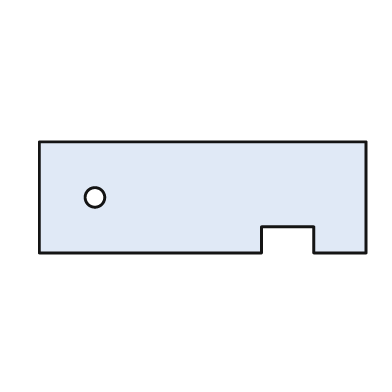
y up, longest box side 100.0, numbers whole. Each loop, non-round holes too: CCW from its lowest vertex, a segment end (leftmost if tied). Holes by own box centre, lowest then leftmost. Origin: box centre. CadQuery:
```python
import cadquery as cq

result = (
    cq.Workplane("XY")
    .moveTo(-50.0, -17.0)
    .lineTo(18.0, -17.0)
    .lineTo(18.0, -9.0)
    .lineTo(34.0, -9.0)
    .lineTo(34.0, -17.0)
    .lineTo(50.0, -17.0)
    .lineTo(50.0, 17.0)
    .lineTo(-50.0, 17.0)
    .close()
    .moveTo(-33.0, 0.0)
    .circle(3.0)
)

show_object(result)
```